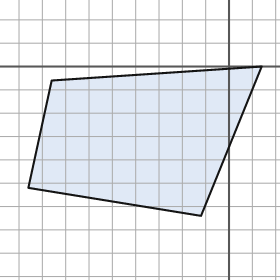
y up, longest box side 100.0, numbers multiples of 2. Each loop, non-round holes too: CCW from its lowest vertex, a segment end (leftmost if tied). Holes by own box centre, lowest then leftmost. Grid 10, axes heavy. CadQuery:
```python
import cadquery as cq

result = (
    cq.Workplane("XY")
    .moveTo(-12.0, -64.0)
    .lineTo(14.0, 0.0)
    .lineTo(-76.0, -6.0)
    .lineTo(-86.0, -52.0)
    .close()
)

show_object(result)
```